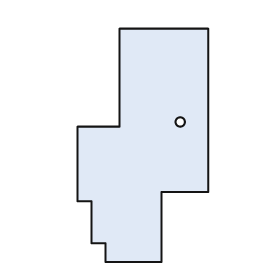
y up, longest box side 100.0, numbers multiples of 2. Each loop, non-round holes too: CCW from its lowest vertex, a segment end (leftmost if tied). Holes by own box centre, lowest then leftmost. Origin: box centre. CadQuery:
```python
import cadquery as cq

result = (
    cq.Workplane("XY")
    .moveTo(-16.0, -50.0)
    .lineTo(8.0, -50.0)
    .lineTo(8.0, -20.0)
    .lineTo(28.0, -20.0)
    .lineTo(28.0, 50.0)
    .lineTo(-10.0, 50.0)
    .lineTo(-10.0, 8.0)
    .lineTo(-28.0, 8.0)
    .lineTo(-28.0, -24.0)
    .lineTo(-22.0, -24.0)
    .lineTo(-22.0, -42.0)
    .lineTo(-16.0, -42.0)
    .close()
    .moveTo(16.0, 10.0)
    .circle(2.0)
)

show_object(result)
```